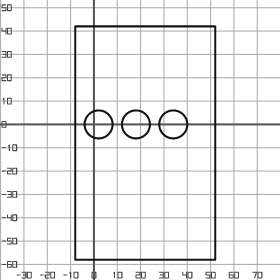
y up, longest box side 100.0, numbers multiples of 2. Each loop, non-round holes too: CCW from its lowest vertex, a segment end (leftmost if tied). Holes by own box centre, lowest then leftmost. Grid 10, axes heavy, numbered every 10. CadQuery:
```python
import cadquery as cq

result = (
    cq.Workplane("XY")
    .moveTo(-8.0, -58.0)
    .lineTo(52.0, -58.0)
    .lineTo(52.0, 42.0)
    .lineTo(-8.0, 42.0)
    .close()
    .moveTo(2.0, 0.0)
    .circle(6.0)
    .moveTo(18.0, 0.0)
    .circle(6.0)
    .moveTo(34.0, 0.0)
    .circle(6.0)
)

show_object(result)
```